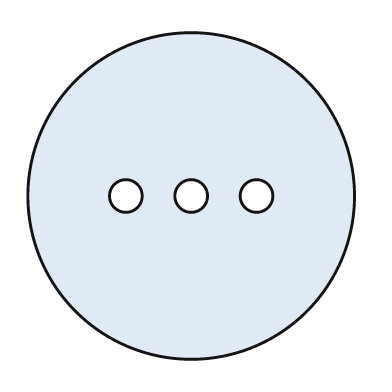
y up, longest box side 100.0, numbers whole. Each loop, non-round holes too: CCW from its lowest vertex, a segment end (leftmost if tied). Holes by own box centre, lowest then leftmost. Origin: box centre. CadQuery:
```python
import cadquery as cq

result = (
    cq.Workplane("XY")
    .moveTo(0.0, 0.0)
    .circle(50.0)
    .moveTo(-20.0, 0.0)
    .circle(5.0)
    .moveTo(0.0, 0.0)
    .circle(5.0)
    .moveTo(20.0, 0.0)
    .circle(5.0)
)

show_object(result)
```